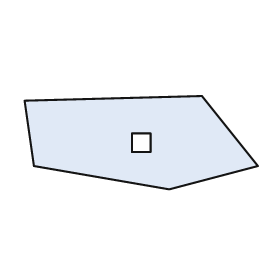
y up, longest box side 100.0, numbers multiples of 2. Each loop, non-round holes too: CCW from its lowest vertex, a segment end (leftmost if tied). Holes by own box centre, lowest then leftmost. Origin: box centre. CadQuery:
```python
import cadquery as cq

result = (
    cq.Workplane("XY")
    .moveTo(12.0, -20.0)
    .lineTo(50.0, -10.0)
    .lineTo(26.0, 20.0)
    .lineTo(-50.0, 18.0)
    .lineTo(-46.0, -10.0)
    .close()
    .moveTo(-4.0, -4.0)
    .lineTo(4.0, -4.0)
    .lineTo(4.0, 4.0)
    .lineTo(-4.0, 4.0)
    .close()
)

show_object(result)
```